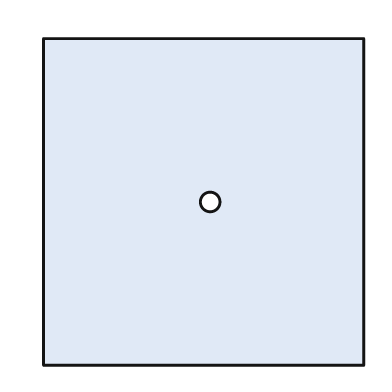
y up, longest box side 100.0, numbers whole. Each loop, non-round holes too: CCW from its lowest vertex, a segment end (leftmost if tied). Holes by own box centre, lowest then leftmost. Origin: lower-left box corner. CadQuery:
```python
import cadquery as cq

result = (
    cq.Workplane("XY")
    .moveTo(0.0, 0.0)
    .lineTo(98.0, 0.0)
    .lineTo(98.0, 100.0)
    .lineTo(0.0, 100.0)
    .close()
    .moveTo(51.0, 50.0)
    .circle(3.0)
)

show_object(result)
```